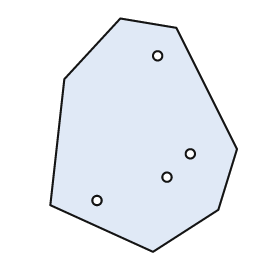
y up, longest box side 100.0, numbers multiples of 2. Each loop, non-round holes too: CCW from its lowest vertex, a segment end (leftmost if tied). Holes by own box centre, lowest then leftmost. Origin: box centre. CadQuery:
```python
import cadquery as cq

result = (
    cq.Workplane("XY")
    .moveTo(4.0, -50.0)
    .lineTo(32.0, -32.0)
    .lineTo(40.0, -6.0)
    .lineTo(14.0, 46.0)
    .lineTo(-10.0, 50.0)
    .lineTo(-34.0, 24.0)
    .lineTo(-40.0, -30.0)
    .close()
    .moveTo(-20.0, -28.0)
    .circle(2.0)
    .moveTo(10.0, -18.0)
    .circle(2.0)
    .moveTo(20.0, -8.0)
    .circle(2.0)
    .moveTo(6.0, 34.0)
    .circle(2.0)
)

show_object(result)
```